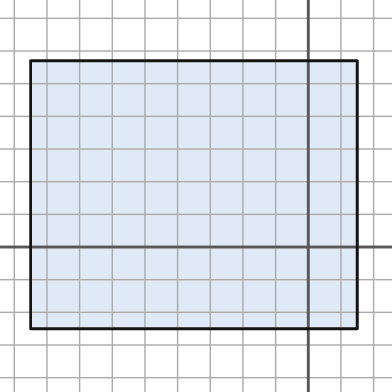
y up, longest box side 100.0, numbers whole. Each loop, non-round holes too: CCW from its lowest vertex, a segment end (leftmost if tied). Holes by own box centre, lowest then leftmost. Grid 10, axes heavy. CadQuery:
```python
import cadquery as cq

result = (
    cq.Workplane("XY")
    .moveTo(-85.0, -25.0)
    .lineTo(15.0, -25.0)
    .lineTo(15.0, 57.0)
    .lineTo(-85.0, 57.0)
    .close()
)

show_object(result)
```